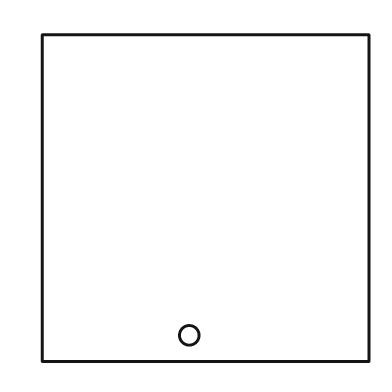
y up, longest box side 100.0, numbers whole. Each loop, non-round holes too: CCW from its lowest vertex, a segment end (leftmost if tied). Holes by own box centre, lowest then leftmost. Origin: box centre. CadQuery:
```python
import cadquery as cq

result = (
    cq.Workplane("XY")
    .moveTo(-50.0, -50.0)
    .lineTo(50.0, -50.0)
    .lineTo(50.0, 50.0)
    .lineTo(-50.0, 50.0)
    .close()
    .moveTo(-5.0, -42.0)
    .circle(3.0)
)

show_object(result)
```